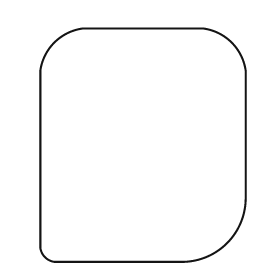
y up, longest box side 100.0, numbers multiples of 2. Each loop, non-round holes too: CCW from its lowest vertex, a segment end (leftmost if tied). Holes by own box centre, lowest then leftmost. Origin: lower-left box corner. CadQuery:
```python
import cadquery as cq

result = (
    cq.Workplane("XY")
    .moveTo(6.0, 0.0)
    .lineTo(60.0, 0.0)
    .threePointArc((80.0, 8.0), (88.0, 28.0))
    .lineTo(88.0, 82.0)
    .threePointArc((82.0, 94.0), (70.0, 100.0))
    .lineTo(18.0, 100.0)
    .threePointArc((6.0, 94.0), (0.0, 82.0))
    .lineTo(0.0, 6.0)
    .threePointArc((2.0, 2.0), (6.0, 0.0))
    .close()
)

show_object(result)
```